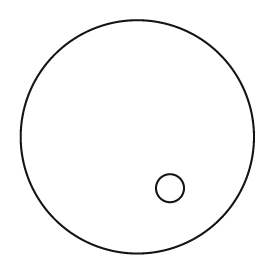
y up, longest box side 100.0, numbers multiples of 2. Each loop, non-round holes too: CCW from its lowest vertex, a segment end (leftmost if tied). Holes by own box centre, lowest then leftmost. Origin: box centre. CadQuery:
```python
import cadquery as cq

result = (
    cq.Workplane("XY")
    .moveTo(0.0, 0.0)
    .circle(50.0)
    .moveTo(14.0, -22.0)
    .circle(6.0)
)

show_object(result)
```